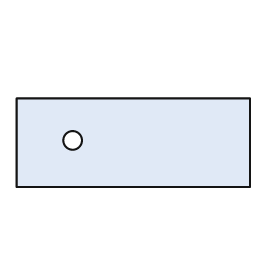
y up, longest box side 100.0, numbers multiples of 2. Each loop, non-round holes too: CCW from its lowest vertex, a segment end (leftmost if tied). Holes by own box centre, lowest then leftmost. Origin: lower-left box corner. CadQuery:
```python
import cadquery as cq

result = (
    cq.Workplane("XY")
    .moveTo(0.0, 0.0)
    .lineTo(100.0, 0.0)
    .lineTo(100.0, 38.0)
    .lineTo(0.0, 38.0)
    .close()
    .moveTo(24.0, 20.0)
    .circle(4.0)
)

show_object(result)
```